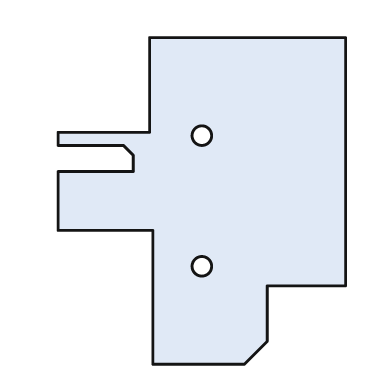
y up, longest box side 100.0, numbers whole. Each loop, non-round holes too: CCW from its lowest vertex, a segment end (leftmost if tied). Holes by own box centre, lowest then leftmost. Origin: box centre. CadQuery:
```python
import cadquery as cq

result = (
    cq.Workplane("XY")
    .moveTo(-15.0, -50.0)
    .lineTo(13.0, -50.0)
    .lineTo(20.0, -43.0)
    .lineTo(20.0, -26.0)
    .lineTo(44.0, -26.0)
    .lineTo(44.0, 50.0)
    .lineTo(-16.0, 50.0)
    .lineTo(-16.0, 21.0)
    .lineTo(-44.0, 21.0)
    .lineTo(-44.0, 17.0)
    .lineTo(-24.0, 17.0)
    .lineTo(-21.0, 14.0)
    .lineTo(-21.0, 9.0)
    .lineTo(-44.0, 9.0)
    .lineTo(-44.0, -9.0)
    .lineTo(-15.0, -9.0)
    .close()
    .moveTo(0.0, -20.0)
    .circle(3.0)
    .moveTo(0.0, 20.0)
    .circle(3.0)
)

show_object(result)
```